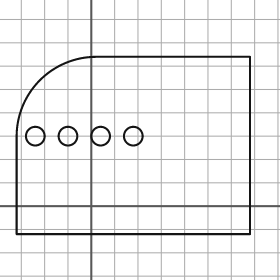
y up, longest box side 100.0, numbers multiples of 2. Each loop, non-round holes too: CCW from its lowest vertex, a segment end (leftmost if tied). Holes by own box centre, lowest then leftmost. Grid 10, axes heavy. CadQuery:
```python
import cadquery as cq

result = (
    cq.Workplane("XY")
    .moveTo(-32.0, -12.0)
    .lineTo(68.0, -12.0)
    .lineTo(68.0, 64.0)
    .lineTo(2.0, 64.0)
    .threePointArc((-22.0, 54.0), (-32.0, 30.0))
    .close()
    .moveTo(-24.0, 30.0)
    .circle(4.0)
    .moveTo(-10.0, 30.0)
    .circle(4.0)
    .moveTo(4.0, 30.0)
    .circle(4.0)
    .moveTo(18.0, 30.0)
    .circle(4.0)
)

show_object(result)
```